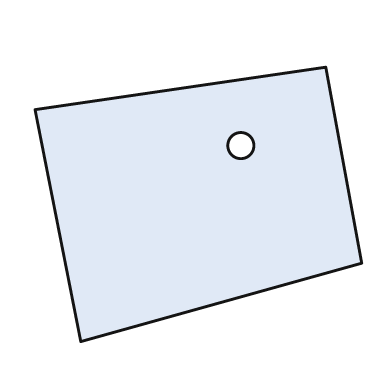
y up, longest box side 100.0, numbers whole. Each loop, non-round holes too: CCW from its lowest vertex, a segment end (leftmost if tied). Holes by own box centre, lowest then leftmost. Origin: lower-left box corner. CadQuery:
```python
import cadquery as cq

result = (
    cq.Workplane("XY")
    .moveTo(14.0, 0.0)
    .lineTo(100.0, 24.0)
    .lineTo(89.0, 84.0)
    .lineTo(0.0, 71.0)
    .close()
    .moveTo(63.0, 60.0)
    .circle(4.0)
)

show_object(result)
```